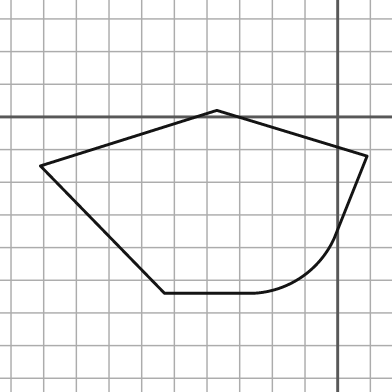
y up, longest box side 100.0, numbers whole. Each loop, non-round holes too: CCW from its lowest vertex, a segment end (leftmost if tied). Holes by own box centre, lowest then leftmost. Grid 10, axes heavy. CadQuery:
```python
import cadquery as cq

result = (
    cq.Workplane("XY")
    .moveTo(-53.0, -54.0)
    .lineTo(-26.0, -54.0)
    .threePointArc((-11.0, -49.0), (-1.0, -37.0))
    .lineTo(9.0, -12.0)
    .lineTo(-37.0, 2.0)
    .lineTo(-91.0, -15.0)
    .close()
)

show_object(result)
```